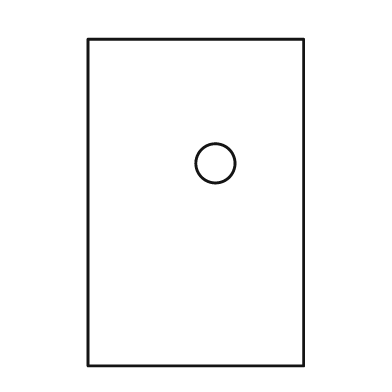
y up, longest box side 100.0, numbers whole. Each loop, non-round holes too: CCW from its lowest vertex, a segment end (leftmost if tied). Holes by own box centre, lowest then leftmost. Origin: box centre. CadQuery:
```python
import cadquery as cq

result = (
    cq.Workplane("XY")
    .moveTo(-33.0, -50.0)
    .lineTo(33.0, -50.0)
    .lineTo(33.0, 50.0)
    .lineTo(-33.0, 50.0)
    .close()
    .moveTo(6.0, 12.0)
    .circle(6.0)
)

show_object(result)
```